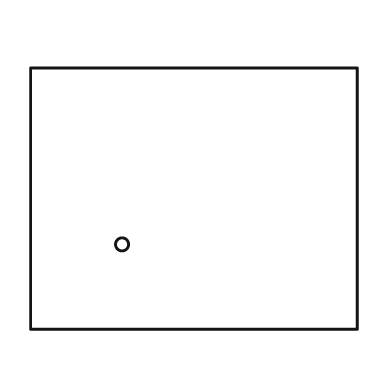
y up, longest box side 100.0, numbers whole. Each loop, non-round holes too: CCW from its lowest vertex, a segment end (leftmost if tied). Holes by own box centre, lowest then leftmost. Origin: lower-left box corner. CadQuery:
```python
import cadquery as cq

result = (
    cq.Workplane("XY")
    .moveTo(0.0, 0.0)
    .lineTo(100.0, 0.0)
    .lineTo(100.0, 80.0)
    .lineTo(0.0, 80.0)
    .close()
    .moveTo(28.0, 26.0)
    .circle(2.0)
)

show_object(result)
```